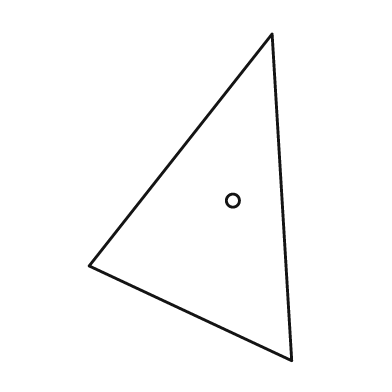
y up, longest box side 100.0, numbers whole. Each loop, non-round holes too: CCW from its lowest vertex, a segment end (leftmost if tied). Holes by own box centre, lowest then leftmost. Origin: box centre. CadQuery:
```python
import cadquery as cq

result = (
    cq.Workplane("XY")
    .moveTo(31.0, -50.0)
    .lineTo(25.0, 50.0)
    .lineTo(-31.0, -21.0)
    .close()
    .moveTo(13.0, -1.0)
    .circle(2.0)
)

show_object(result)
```